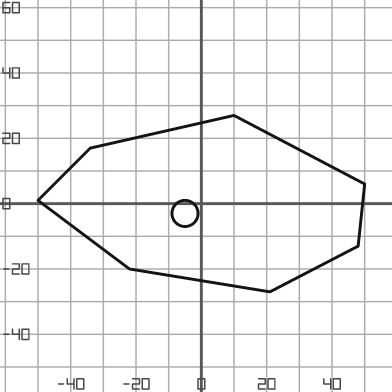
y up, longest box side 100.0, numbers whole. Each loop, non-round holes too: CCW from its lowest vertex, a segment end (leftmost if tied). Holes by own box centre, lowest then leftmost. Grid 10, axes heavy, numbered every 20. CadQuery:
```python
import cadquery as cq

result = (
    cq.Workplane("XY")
    .moveTo(21.0, -27.0)
    .lineTo(48.0, -13.0)
    .lineTo(50.0, 6.0)
    .lineTo(10.0, 27.0)
    .lineTo(-34.0, 17.0)
    .lineTo(-50.0, 1.0)
    .lineTo(-22.0, -20.0)
    .close()
    .moveTo(-5.0, -3.0)
    .circle(4.0)
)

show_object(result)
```